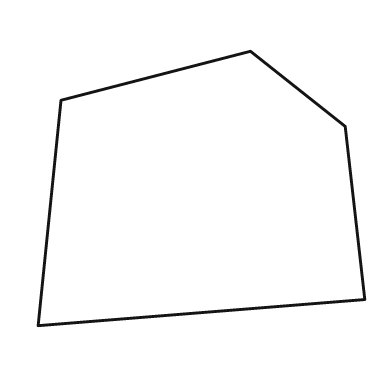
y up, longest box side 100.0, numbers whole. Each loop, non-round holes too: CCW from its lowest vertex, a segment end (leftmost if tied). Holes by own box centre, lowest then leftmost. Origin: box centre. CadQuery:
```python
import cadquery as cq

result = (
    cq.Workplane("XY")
    .moveTo(-50.0, -42.0)
    .lineTo(50.0, -34.0)
    .lineTo(44.0, 19.0)
    .lineTo(15.0, 42.0)
    .lineTo(-43.0, 27.0)
    .close()
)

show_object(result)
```